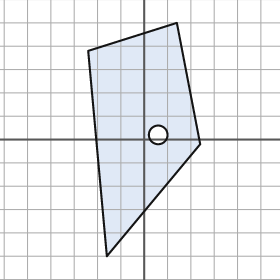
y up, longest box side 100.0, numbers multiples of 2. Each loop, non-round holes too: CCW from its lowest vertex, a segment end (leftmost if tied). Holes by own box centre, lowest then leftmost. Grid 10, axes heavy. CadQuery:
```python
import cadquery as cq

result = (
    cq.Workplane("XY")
    .moveTo(-16.0, -50.0)
    .lineTo(24.0, -2.0)
    .lineTo(14.0, 50.0)
    .lineTo(-24.0, 38.0)
    .close()
    .moveTo(6.0, 2.0)
    .circle(4.0)
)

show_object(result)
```